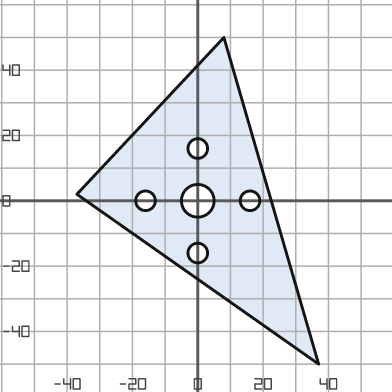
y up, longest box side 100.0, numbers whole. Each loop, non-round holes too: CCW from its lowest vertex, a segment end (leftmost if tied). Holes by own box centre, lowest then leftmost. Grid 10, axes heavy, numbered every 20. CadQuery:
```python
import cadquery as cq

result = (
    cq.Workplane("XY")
    .moveTo(37.0, -50.0)
    .lineTo(8.0, 50.0)
    .lineTo(-37.0, 2.0)
    .close()
    .moveTo(0.0, -16.0)
    .circle(3.0)
    .moveTo(-16.0, 0.0)
    .circle(3.0)
    .moveTo(0.0, 0.0)
    .circle(5.0)
    .moveTo(16.0, 0.0)
    .circle(3.0)
    .moveTo(0.0, 16.0)
    .circle(3.0)
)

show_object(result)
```